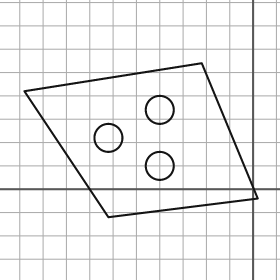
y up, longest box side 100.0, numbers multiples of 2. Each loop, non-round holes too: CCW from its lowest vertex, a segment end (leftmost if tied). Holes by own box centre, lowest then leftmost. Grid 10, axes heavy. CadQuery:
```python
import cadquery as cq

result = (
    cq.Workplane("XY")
    .moveTo(-62.0, -12.0)
    .lineTo(2.0, -4.0)
    .lineTo(-22.0, 54.0)
    .lineTo(-98.0, 42.0)
    .close()
    .moveTo(-40.0, 10.0)
    .circle(6.0)
    .moveTo(-62.0, 22.0)
    .circle(6.0)
    .moveTo(-40.0, 34.0)
    .circle(6.0)
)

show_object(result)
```